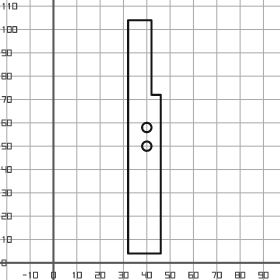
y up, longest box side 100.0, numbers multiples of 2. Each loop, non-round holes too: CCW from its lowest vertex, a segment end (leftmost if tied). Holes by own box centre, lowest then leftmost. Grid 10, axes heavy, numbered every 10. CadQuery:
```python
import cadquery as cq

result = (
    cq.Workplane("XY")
    .moveTo(32.0, 4.0)
    .lineTo(46.0, 4.0)
    .lineTo(46.0, 72.0)
    .lineTo(42.0, 72.0)
    .lineTo(42.0, 104.0)
    .lineTo(32.0, 104.0)
    .close()
    .moveTo(40.0, 50.0)
    .circle(2.0)
    .moveTo(40.0, 58.0)
    .circle(2.0)
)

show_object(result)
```